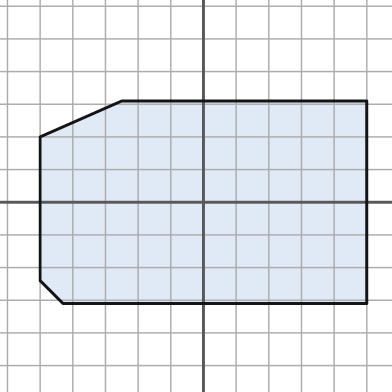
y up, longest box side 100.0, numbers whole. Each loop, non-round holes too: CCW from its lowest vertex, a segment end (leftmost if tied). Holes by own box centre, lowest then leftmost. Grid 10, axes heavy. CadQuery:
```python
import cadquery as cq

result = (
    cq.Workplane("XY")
    .moveTo(-43.0, -31.0)
    .lineTo(50.0, -31.0)
    .lineTo(50.0, 31.0)
    .lineTo(-25.0, 31.0)
    .lineTo(-50.0, 20.0)
    .lineTo(-50.0, -24.0)
    .close()
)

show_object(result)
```